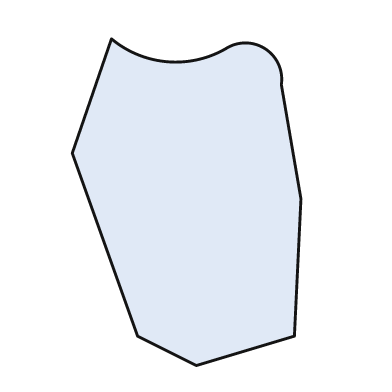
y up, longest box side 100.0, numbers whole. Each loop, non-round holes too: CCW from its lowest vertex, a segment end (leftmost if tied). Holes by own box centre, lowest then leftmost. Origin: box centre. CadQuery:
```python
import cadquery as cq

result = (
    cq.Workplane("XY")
    .moveTo(3.0, -50.0)
    .lineTo(33.0, -41.0)
    .lineTo(35.0, 1.0)
    .lineTo(29.0, 36.0)
    .threePointArc((24.0, 47.0), (12.0, 47.0))
    .threePointArc((-6.0, 43.0), (-23.0, 50.0))
    .lineTo(-35.0, 15.0)
    .lineTo(-15.0, -41.0)
    .close()
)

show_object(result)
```